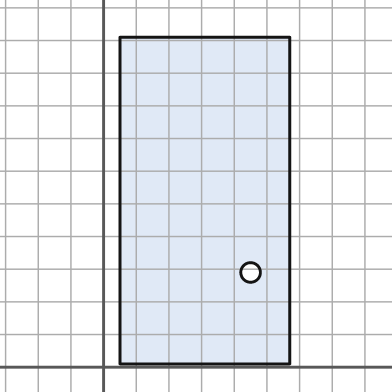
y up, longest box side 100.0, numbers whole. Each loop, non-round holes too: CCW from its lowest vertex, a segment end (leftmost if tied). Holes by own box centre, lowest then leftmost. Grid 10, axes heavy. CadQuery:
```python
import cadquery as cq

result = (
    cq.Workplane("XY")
    .moveTo(5.0, 1.0)
    .lineTo(57.0, 1.0)
    .lineTo(57.0, 101.0)
    .lineTo(5.0, 101.0)
    .close()
    .moveTo(45.0, 29.0)
    .circle(3.0)
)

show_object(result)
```